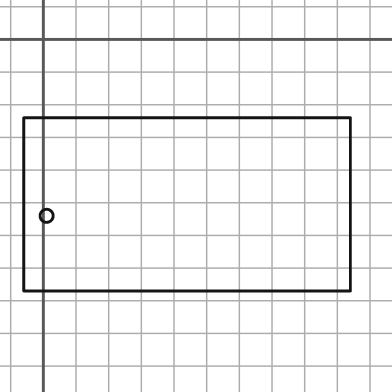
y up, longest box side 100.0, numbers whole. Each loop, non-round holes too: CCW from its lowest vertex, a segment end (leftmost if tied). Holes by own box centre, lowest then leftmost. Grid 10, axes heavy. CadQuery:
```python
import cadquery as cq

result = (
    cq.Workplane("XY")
    .moveTo(-6.0, -77.0)
    .lineTo(94.0, -77.0)
    .lineTo(94.0, -24.0)
    .lineTo(-6.0, -24.0)
    .close()
    .moveTo(1.0, -54.0)
    .circle(2.0)
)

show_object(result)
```